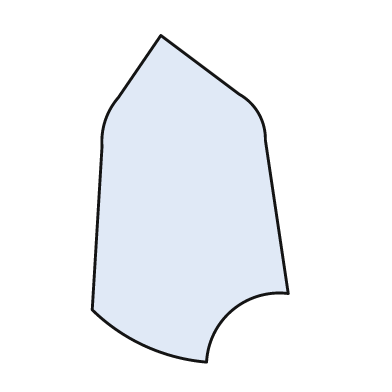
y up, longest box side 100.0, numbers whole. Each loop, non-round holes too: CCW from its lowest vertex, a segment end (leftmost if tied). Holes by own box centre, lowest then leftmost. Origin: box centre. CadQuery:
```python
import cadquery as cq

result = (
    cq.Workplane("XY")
    .moveTo(5.0, -50.0)
    .threePointArc((13.0, -34.0), (30.0, -29.0))
    .lineTo(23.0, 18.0)
    .threePointArc((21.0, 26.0), (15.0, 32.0))
    .lineTo(-9.0, 50.0)
    .lineTo(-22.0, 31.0)
    .threePointArc((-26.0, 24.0), (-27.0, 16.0))
    .lineTo(-30.0, -34.0)
    .threePointArc((-14.0, -45.0), (5.0, -50.0))
    .close()
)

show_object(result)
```